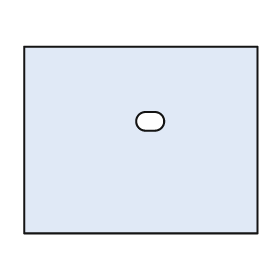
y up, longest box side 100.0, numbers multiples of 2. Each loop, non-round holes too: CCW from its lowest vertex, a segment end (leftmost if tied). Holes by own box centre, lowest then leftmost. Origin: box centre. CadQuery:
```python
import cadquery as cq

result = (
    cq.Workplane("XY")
    .moveTo(-50.0, -40.0)
    .lineTo(50.0, -40.0)
    .lineTo(50.0, 40.0)
    .lineTo(-50.0, 40.0)
    .close()
    .moveTo(2.0, 4.0)
    .lineTo(6.0, 4.0)
    .threePointArc((10.0, 8.0), (6.0, 12.0))
    .lineTo(2.0, 12.0)
    .threePointArc((-2.0, 8.0), (2.0, 4.0))
    .close()
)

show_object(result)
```